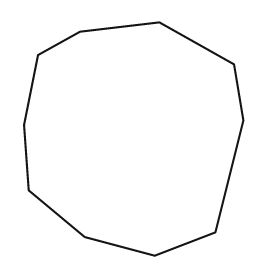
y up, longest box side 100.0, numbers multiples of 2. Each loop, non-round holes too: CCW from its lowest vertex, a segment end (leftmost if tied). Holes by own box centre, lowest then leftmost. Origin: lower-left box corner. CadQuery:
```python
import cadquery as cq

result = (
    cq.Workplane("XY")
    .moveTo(56.0, 0.0)
    .lineTo(82.0, 10.0)
    .lineTo(94.0, 58.0)
    .lineTo(90.0, 82.0)
    .lineTo(58.0, 100.0)
    .lineTo(24.0, 96.0)
    .lineTo(6.0, 86.0)
    .lineTo(0.0, 56.0)
    .lineTo(2.0, 28.0)
    .lineTo(26.0, 8.0)
    .close()
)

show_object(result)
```